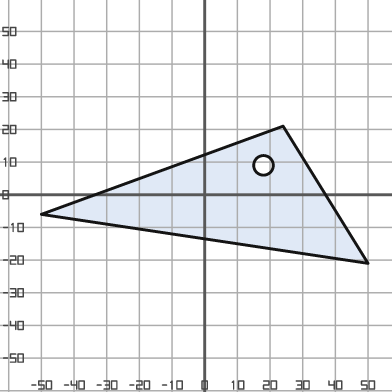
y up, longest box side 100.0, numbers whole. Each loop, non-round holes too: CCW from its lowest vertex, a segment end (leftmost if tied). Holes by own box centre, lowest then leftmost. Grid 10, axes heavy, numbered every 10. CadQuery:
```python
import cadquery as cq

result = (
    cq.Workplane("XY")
    .moveTo(50.0, -21.0)
    .lineTo(24.0, 21.0)
    .lineTo(-50.0, -6.0)
    .close()
    .moveTo(18.0, 9.0)
    .circle(3.0)
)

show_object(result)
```